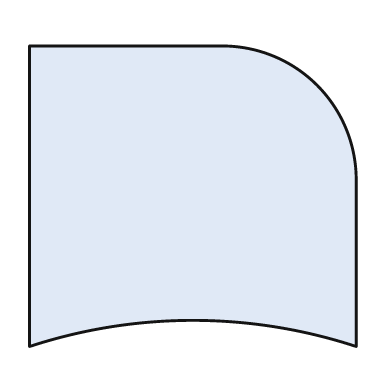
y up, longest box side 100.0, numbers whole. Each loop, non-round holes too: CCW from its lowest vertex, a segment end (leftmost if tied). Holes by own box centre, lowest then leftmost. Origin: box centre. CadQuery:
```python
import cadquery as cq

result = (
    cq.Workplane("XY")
    .moveTo(-50.0, -46.0)
    .threePointArc((0.0, -38.0), (50.0, -46.0))
    .lineTo(50.0, 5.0)
    .threePointArc((38.0, 34.0), (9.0, 46.0))
    .lineTo(-50.0, 46.0)
    .close()
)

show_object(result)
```